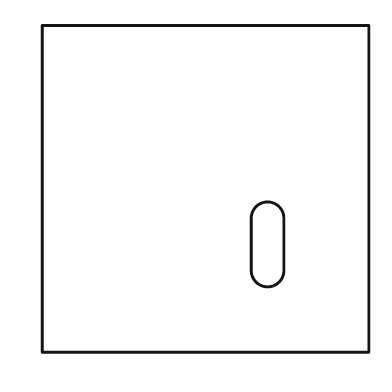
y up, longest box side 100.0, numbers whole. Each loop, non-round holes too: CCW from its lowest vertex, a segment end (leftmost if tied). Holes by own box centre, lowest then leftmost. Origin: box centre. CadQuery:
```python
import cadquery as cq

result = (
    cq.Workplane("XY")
    .moveTo(-50.0, -50.0)
    .lineTo(50.0, -50.0)
    .lineTo(50.0, 50.0)
    .lineTo(-50.0, 50.0)
    .close()
    .moveTo(14.0, -25.0)
    .threePointArc((19.0, -30.0), (24.0, -25.0))
    .lineTo(24.0, -9.0)
    .threePointArc((19.0, -4.0), (14.0, -9.0))
    .close()
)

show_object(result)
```